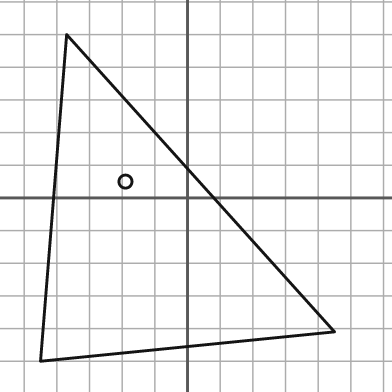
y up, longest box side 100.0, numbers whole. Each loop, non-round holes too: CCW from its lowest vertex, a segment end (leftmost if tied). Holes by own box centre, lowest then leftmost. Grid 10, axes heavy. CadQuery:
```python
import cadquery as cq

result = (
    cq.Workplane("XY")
    .moveTo(-45.0, -50.0)
    .lineTo(45.0, -41.0)
    .lineTo(-37.0, 50.0)
    .close()
    .moveTo(-19.0, 5.0)
    .circle(2.0)
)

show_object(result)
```